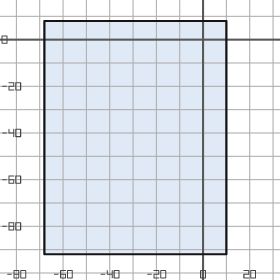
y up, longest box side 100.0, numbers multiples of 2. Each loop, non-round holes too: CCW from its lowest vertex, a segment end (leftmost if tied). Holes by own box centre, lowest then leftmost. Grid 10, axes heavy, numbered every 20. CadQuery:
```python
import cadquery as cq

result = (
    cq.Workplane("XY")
    .moveTo(-68.0, -92.0)
    .lineTo(10.0, -92.0)
    .lineTo(10.0, 8.0)
    .lineTo(-68.0, 8.0)
    .close()
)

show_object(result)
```